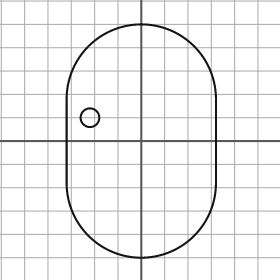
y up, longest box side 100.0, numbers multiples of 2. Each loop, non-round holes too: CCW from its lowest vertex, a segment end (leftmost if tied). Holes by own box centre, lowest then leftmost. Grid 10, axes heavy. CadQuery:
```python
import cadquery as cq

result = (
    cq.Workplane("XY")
    .moveTo(-32.0, -18.0)
    .threePointArc((0.0, -50.0), (32.0, -18.0))
    .lineTo(32.0, 18.0)
    .threePointArc((0.0, 50.0), (-32.0, 18.0))
    .close()
    .moveTo(-22.0, 10.0)
    .circle(4.0)
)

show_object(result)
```